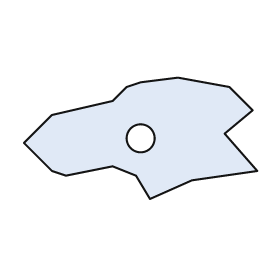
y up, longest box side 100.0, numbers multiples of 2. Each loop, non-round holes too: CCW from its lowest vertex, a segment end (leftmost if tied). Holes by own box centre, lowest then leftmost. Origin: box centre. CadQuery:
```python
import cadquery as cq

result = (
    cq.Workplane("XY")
    .moveTo(4.0, -26.0)
    .lineTo(22.0, -18.0)
    .lineTo(50.0, -14.0)
    .lineTo(36.0, 2.0)
    .lineTo(48.0, 12.0)
    .lineTo(38.0, 22.0)
    .lineTo(16.0, 26.0)
    .lineTo(0.0, 24.0)
    .lineTo(-6.0, 22.0)
    .lineTo(-12.0, 16.0)
    .lineTo(-38.0, 10.0)
    .lineTo(-50.0, -2.0)
    .lineTo(-38.0, -14.0)
    .lineTo(-32.0, -16.0)
    .lineTo(-12.0, -12.0)
    .lineTo(-2.0, -16.0)
    .close()
    .moveTo(0.0, 0.0)
    .circle(6.0)
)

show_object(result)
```